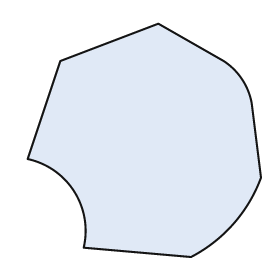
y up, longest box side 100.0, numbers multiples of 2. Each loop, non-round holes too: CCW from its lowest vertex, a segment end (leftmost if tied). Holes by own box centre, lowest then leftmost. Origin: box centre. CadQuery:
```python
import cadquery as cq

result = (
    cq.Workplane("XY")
    .moveTo(20.0, -50.0)
    .threePointArc((38.0, -36.0), (50.0, -16.0))
    .lineTo(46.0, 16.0)
    .threePointArc((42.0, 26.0), (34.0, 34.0))
    .lineTo(6.0, 50.0)
    .lineTo(-36.0, 34.0)
    .lineTo(-50.0, -8.0)
    .threePointArc((-30.0, -22.0), (-26.0, -46.0))
    .close()
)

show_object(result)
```